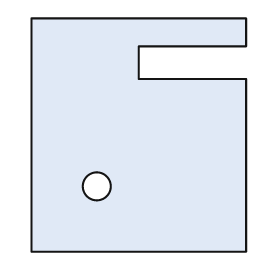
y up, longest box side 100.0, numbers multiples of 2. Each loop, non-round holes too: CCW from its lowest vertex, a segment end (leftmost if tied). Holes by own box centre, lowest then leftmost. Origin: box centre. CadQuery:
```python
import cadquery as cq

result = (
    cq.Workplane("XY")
    .moveTo(-46.0, -50.0)
    .lineTo(46.0, -50.0)
    .lineTo(46.0, 24.0)
    .lineTo(0.0, 24.0)
    .lineTo(0.0, 38.0)
    .lineTo(46.0, 38.0)
    .lineTo(46.0, 50.0)
    .lineTo(-46.0, 50.0)
    .close()
    .moveTo(-18.0, -22.0)
    .circle(6.0)
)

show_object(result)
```